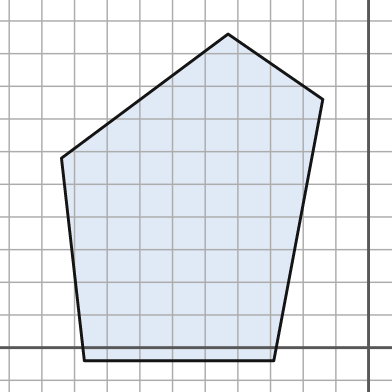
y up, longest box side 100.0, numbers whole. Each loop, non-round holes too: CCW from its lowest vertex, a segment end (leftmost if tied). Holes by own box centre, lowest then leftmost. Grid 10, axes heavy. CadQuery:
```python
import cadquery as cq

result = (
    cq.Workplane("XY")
    .moveTo(-87.0, -4.0)
    .lineTo(-29.0, -4.0)
    .lineTo(-14.0, 76.0)
    .lineTo(-43.0, 96.0)
    .lineTo(-94.0, 58.0)
    .close()
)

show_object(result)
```